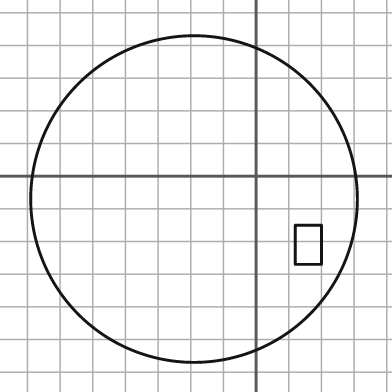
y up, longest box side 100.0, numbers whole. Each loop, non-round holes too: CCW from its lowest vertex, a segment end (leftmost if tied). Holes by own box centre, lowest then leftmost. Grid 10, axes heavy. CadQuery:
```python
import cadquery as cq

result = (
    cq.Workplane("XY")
    .moveTo(-19.0, -7.0)
    .circle(50.0)
    .moveTo(12.0, -27.0)
    .lineTo(20.0, -27.0)
    .lineTo(20.0, -15.0)
    .lineTo(12.0, -15.0)
    .close()
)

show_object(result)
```